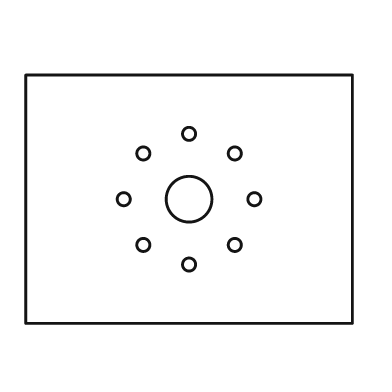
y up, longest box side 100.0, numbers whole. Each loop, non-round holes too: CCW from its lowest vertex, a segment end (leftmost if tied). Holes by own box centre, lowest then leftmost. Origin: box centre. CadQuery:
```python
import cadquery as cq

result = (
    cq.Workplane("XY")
    .moveTo(-50.0, -38.0)
    .lineTo(50.0, -38.0)
    .lineTo(50.0, 38.0)
    .lineTo(-50.0, 38.0)
    .close()
    .moveTo(0.0, -20.0)
    .circle(2.0)
    .moveTo(-14.0, -14.0)
    .circle(2.0)
    .moveTo(14.0, -14.0)
    .circle(2.0)
    .moveTo(-20.0, 0.0)
    .circle(2.0)
    .moveTo(0.0, 0.0)
    .circle(7.0)
    .moveTo(20.0, 0.0)
    .circle(2.0)
    .moveTo(-14.0, 14.0)
    .circle(2.0)
    .moveTo(14.0, 14.0)
    .circle(2.0)
    .moveTo(0.0, 20.0)
    .circle(2.0)
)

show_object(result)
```